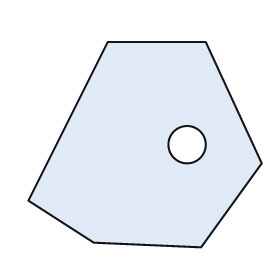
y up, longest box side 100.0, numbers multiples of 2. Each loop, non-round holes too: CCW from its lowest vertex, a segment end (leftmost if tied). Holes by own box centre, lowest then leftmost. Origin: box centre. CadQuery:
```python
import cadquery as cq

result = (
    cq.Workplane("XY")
    .moveTo(24.0, -44.0)
    .lineTo(50.0, -8.0)
    .lineTo(26.0, 44.0)
    .lineTo(-16.0, 44.0)
    .lineTo(-50.0, -24.0)
    .lineTo(-22.0, -42.0)
    .close()
    .moveTo(18.0, 0.0)
    .circle(8.0)
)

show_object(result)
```